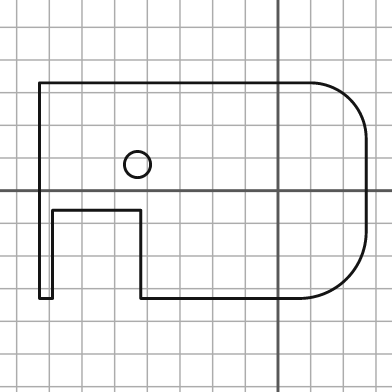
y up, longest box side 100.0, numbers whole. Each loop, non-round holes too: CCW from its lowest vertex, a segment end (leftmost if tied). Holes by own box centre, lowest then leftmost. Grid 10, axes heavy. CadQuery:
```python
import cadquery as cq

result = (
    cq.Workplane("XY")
    .moveTo(-73.0, -33.0)
    .lineTo(-69.0, -33.0)
    .lineTo(-69.0, -6.0)
    .lineTo(-42.0, -6.0)
    .lineTo(-42.0, -33.0)
    .lineTo(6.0, -33.0)
    .threePointArc((21.0, -27.0), (27.0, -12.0))
    .lineTo(27.0, 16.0)
    .threePointArc((22.0, 28.0), (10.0, 33.0))
    .lineTo(-73.0, 33.0)
    .close()
    .moveTo(-43.0, 8.0)
    .circle(4.0)
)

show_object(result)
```